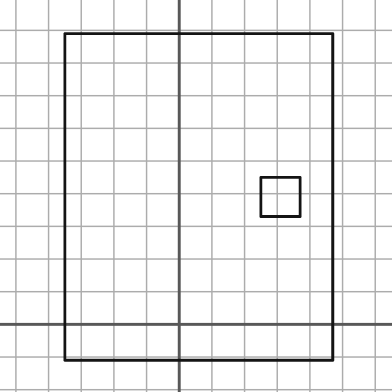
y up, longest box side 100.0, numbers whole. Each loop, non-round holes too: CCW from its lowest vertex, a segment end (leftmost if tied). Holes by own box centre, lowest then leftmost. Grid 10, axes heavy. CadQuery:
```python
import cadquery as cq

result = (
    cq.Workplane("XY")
    .moveTo(-35.0, -11.0)
    .lineTo(47.0, -11.0)
    .lineTo(47.0, 89.0)
    .lineTo(-35.0, 89.0)
    .close()
    .moveTo(25.0, 33.0)
    .lineTo(37.0, 33.0)
    .lineTo(37.0, 45.0)
    .lineTo(25.0, 45.0)
    .close()
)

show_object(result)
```